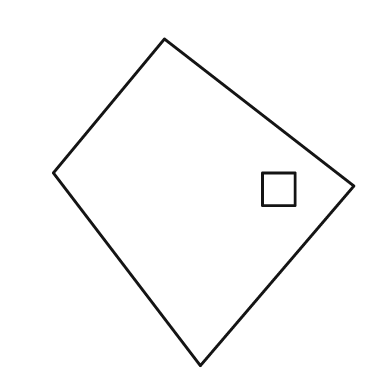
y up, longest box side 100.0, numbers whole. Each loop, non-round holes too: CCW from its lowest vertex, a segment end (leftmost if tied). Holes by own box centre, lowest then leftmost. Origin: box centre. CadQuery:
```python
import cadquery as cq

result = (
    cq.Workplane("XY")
    .moveTo(-1.0, -50.0)
    .lineTo(46.0, 5.0)
    .lineTo(-12.0, 50.0)
    .lineTo(-46.0, 9.0)
    .close()
    .moveTo(18.0, -1.0)
    .lineTo(28.0, -1.0)
    .lineTo(28.0, 9.0)
    .lineTo(18.0, 9.0)
    .close()
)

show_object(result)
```